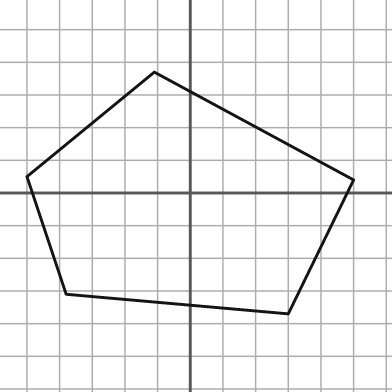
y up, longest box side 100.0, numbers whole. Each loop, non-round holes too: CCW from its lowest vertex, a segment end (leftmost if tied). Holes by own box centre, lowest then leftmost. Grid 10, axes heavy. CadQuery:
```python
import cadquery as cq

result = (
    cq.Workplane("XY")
    .moveTo(30.0, -37.0)
    .lineTo(50.0, 4.0)
    .lineTo(-11.0, 37.0)
    .lineTo(-50.0, 5.0)
    .lineTo(-38.0, -31.0)
    .close()
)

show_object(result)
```